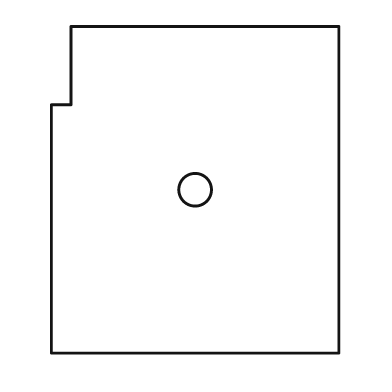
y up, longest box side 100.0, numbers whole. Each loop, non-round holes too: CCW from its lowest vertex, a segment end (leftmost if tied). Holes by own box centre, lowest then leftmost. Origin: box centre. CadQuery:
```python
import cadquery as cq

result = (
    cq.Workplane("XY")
    .moveTo(-44.0, -50.0)
    .lineTo(44.0, -50.0)
    .lineTo(44.0, 50.0)
    .lineTo(-38.0, 50.0)
    .lineTo(-38.0, 26.0)
    .lineTo(-44.0, 26.0)
    .close()
    .moveTo(0.0, 0.0)
    .circle(5.0)
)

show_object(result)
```